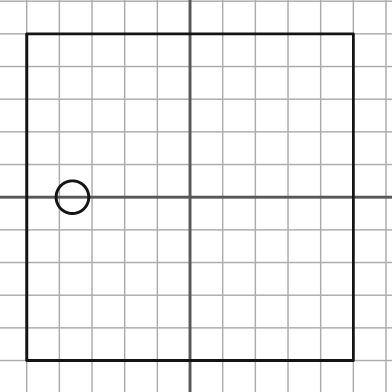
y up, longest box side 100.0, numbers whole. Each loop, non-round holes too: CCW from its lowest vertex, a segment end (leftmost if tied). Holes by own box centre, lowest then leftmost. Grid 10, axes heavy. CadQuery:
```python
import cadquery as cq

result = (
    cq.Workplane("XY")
    .moveTo(-50.0, -50.0)
    .lineTo(50.0, -50.0)
    .lineTo(50.0, 50.0)
    .lineTo(-50.0, 50.0)
    .close()
    .moveTo(-36.0, 0.0)
    .circle(5.0)
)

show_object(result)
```